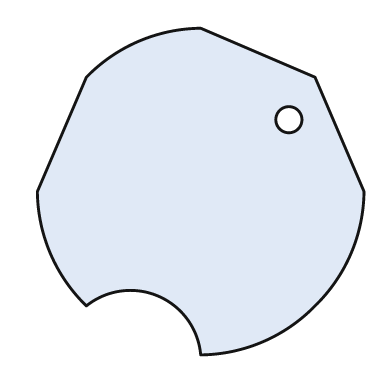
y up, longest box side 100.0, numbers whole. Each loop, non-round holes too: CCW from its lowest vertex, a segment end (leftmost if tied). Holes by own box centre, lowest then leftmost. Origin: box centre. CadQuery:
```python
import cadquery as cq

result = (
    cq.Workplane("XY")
    .moveTo(0.0, -50.0)
    .threePointArc((19.0, -46.0), (35.0, -35.0))
    .threePointArc((46.0, -19.0), (50.0, 0.0))
    .lineTo(35.0, 35.0)
    .lineTo(0.0, 50.0)
    .threePointArc((-19.0, 46.0), (-35.0, 35.0))
    .lineTo(-50.0, 0.0)
    .threePointArc((-46.0, -19.0), (-35.0, -35.0))
    .threePointArc((-13.0, -32.0), (0.0, -50.0))
    .close()
    .moveTo(27.0, 22.0)
    .circle(4.0)
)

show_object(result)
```